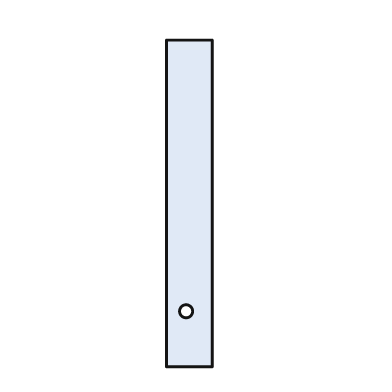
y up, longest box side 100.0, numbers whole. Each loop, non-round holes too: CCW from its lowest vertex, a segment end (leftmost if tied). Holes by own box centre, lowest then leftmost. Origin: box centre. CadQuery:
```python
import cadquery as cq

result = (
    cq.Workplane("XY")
    .moveTo(-7.0, -50.0)
    .lineTo(7.0, -50.0)
    .lineTo(7.0, 50.0)
    .lineTo(-7.0, 50.0)
    .close()
    .moveTo(-1.0, -33.0)
    .circle(2.0)
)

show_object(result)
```